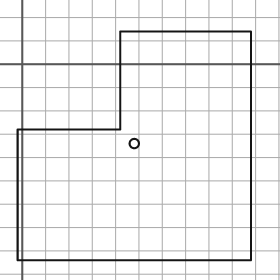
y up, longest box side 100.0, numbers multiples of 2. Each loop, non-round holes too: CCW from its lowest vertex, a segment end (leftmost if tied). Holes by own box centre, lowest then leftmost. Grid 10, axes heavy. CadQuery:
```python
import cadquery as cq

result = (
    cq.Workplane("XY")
    .moveTo(-2.0, -84.0)
    .lineTo(98.0, -84.0)
    .lineTo(98.0, 14.0)
    .lineTo(42.0, 14.0)
    .lineTo(42.0, -28.0)
    .lineTo(-2.0, -28.0)
    .close()
    .moveTo(48.0, -34.0)
    .circle(2.0)
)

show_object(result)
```